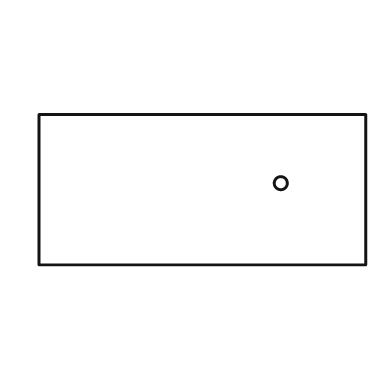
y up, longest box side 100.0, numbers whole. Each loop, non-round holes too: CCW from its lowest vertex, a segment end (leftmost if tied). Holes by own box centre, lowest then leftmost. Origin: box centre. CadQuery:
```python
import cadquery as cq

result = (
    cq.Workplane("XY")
    .moveTo(-50.0, -23.0)
    .lineTo(50.0, -23.0)
    .lineTo(50.0, 23.0)
    .lineTo(-50.0, 23.0)
    .close()
    .moveTo(24.0, 2.0)
    .circle(2.0)
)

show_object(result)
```